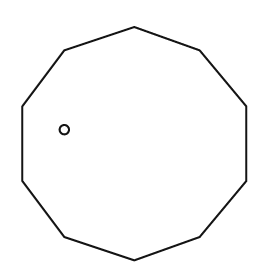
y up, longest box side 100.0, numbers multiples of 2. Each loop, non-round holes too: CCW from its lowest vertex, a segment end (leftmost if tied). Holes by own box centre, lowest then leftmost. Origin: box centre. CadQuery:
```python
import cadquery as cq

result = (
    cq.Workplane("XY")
    .moveTo(0.0, -50.0)
    .lineTo(28.0, -40.0)
    .lineTo(48.0, -16.0)
    .lineTo(48.0, 16.0)
    .lineTo(28.0, 40.0)
    .lineTo(0.0, 50.0)
    .lineTo(-30.0, 40.0)
    .lineTo(-48.0, 16.0)
    .lineTo(-48.0, -16.0)
    .lineTo(-30.0, -40.0)
    .close()
    .moveTo(-30.0, 6.0)
    .circle(2.0)
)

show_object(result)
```